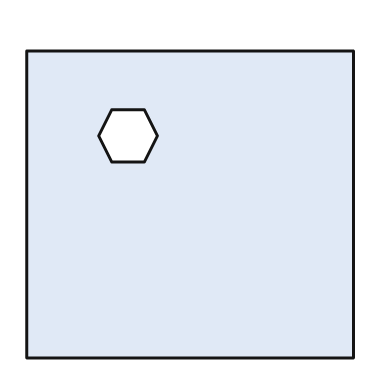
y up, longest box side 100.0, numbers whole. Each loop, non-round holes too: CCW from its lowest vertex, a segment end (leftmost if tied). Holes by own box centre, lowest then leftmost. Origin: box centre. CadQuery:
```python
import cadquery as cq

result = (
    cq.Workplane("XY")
    .moveTo(-50.0, -47.0)
    .lineTo(50.0, -47.0)
    .lineTo(50.0, 47.0)
    .lineTo(-50.0, 47.0)
    .close()
    .moveTo(-24.0, 13.0)
    .lineTo(-14.0, 13.0)
    .lineTo(-10.0, 21.0)
    .lineTo(-14.0, 29.0)
    .lineTo(-24.0, 29.0)
    .lineTo(-28.0, 21.0)
    .close()
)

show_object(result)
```